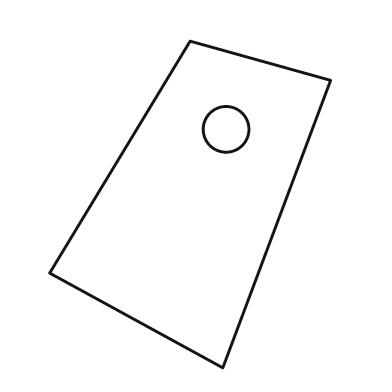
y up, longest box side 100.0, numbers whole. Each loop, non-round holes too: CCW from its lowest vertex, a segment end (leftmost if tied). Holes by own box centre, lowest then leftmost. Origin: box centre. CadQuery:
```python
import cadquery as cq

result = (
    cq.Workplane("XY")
    .moveTo(10.0, -50.0)
    .lineTo(43.0, 38.0)
    .lineTo(0.0, 50.0)
    .lineTo(-43.0, -21.0)
    .close()
    .moveTo(11.0, 23.0)
    .circle(7.0)
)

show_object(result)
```